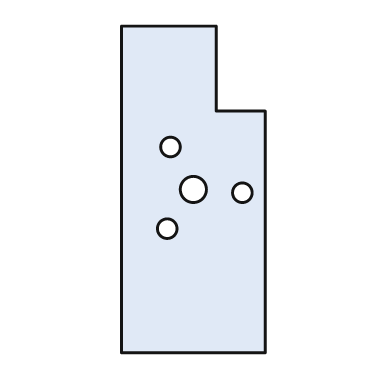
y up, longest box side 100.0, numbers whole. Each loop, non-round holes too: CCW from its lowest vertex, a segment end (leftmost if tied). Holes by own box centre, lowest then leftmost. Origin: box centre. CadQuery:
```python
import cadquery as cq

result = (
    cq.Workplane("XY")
    .moveTo(-22.0, -50.0)
    .lineTo(22.0, -50.0)
    .lineTo(22.0, 24.0)
    .lineTo(7.0, 24.0)
    .lineTo(7.0, 50.0)
    .lineTo(-22.0, 50.0)
    .close()
    .moveTo(-8.0, -12.0)
    .circle(3.0)
    .moveTo(15.0, -1.0)
    .circle(3.0)
    .moveTo(0.0, 0.0)
    .circle(4.0)
    .moveTo(-7.0, 13.0)
    .circle(3.0)
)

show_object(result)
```